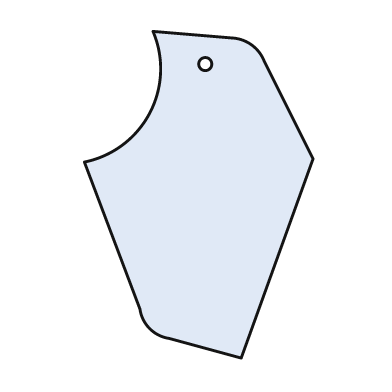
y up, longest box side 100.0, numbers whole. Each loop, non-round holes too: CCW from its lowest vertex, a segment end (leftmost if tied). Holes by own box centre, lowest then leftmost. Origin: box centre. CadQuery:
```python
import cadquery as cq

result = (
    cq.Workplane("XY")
    .moveTo(13.0, -50.0)
    .lineTo(35.0, 11.0)
    .lineTo(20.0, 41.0)
    .threePointArc((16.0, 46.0), (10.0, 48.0))
    .lineTo(-14.0, 50.0)
    .threePointArc((-15.0, 25.0), (-35.0, 10.0))
    .lineTo(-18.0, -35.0)
    .threePointArc((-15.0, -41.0), (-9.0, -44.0))
    .close()
    .moveTo(2.0, 40.0)
    .circle(2.0)
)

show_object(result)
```